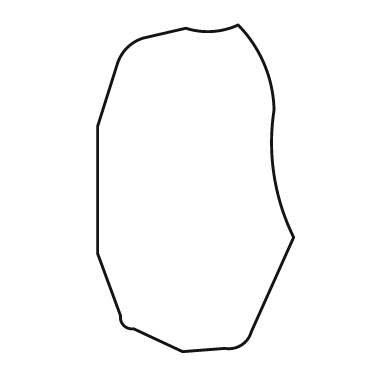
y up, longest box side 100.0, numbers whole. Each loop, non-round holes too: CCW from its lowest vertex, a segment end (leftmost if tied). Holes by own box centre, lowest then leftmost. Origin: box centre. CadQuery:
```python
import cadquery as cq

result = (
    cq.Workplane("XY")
    .moveTo(-4.0, -50.0)
    .lineTo(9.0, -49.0)
    .threePointArc((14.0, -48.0), (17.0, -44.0))
    .lineTo(30.0, -15.0)
    .threePointArc((24.0, 4.0), (24.0, 24.0))
    .threePointArc((21.0, 38.0), (13.0, 50.0))
    .threePointArc((5.0, 48.0), (-3.0, 49.0))
    .lineTo(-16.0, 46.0)
    .threePointArc((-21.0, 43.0), (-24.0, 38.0))
    .lineTo(-30.0, 19.0)
    .lineTo(-30.0, -20.0)
    .lineTo(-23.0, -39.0)
    .threePointArc((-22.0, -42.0), (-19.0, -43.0))
    .close()
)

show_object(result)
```